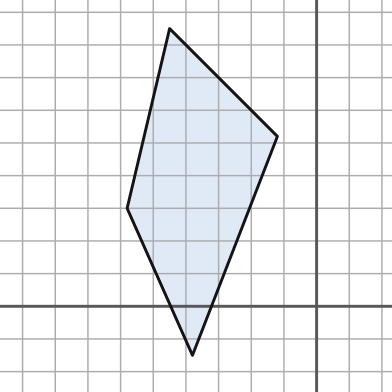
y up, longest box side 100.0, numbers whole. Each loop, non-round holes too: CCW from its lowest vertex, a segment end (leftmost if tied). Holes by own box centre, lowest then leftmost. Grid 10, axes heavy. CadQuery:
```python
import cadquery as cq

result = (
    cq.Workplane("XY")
    .moveTo(-38.0, -15.0)
    .lineTo(-12.0, 52.0)
    .lineTo(-45.0, 85.0)
    .lineTo(-58.0, 30.0)
    .close()
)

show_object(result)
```